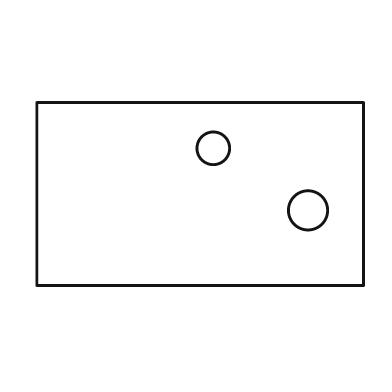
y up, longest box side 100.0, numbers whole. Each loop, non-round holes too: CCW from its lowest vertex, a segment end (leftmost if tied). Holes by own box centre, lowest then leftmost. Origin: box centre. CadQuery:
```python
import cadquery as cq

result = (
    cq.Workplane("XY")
    .moveTo(-50.0, -28.0)
    .lineTo(50.0, -28.0)
    .lineTo(50.0, 28.0)
    .lineTo(-50.0, 28.0)
    .close()
    .moveTo(33.0, -5.0)
    .circle(6.0)
    .moveTo(4.0, 14.0)
    .circle(5.0)
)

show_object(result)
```